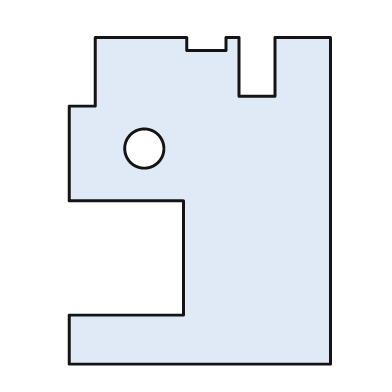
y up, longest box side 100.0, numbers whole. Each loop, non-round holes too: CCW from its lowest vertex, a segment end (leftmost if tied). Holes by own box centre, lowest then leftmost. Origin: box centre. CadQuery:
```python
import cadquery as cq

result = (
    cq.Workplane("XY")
    .moveTo(-40.0, -50.0)
    .lineTo(40.0, -50.0)
    .lineTo(40.0, 50.0)
    .lineTo(23.0, 50.0)
    .lineTo(23.0, 32.0)
    .lineTo(12.0, 32.0)
    .lineTo(12.0, 50.0)
    .lineTo(8.0, 50.0)
    .lineTo(8.0, 46.0)
    .lineTo(-4.0, 46.0)
    .lineTo(-4.0, 50.0)
    .lineTo(-32.0, 50.0)
    .lineTo(-32.0, 29.0)
    .lineTo(-40.0, 29.0)
    .lineTo(-40.0, 0.0)
    .lineTo(-5.0, 0.0)
    .lineTo(-5.0, -35.0)
    .lineTo(-40.0, -35.0)
    .close()
    .moveTo(-17.0, 16.0)
    .circle(6.0)
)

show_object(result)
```